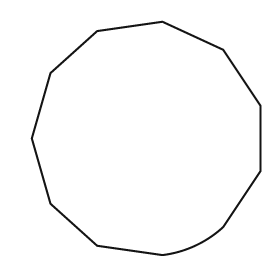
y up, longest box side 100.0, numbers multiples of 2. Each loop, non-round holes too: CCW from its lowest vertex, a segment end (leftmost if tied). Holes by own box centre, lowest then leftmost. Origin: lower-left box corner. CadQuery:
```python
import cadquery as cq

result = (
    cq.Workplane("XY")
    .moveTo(56.0, 0.0)
    .threePointArc((70.0, 4.0), (82.0, 12.0))
    .lineTo(98.0, 36.0)
    .lineTo(98.0, 64.0)
    .lineTo(82.0, 88.0)
    .lineTo(56.0, 100.0)
    .lineTo(28.0, 96.0)
    .lineTo(8.0, 78.0)
    .lineTo(0.0, 50.0)
    .lineTo(8.0, 22.0)
    .lineTo(28.0, 4.0)
    .close()
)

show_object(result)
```